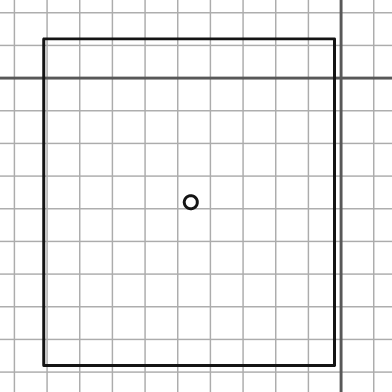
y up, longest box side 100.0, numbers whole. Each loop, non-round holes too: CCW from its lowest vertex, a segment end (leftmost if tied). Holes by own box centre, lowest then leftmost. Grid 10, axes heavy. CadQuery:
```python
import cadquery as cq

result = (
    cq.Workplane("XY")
    .moveTo(-91.0, -88.0)
    .lineTo(-2.0, -88.0)
    .lineTo(-2.0, 12.0)
    .lineTo(-91.0, 12.0)
    .close()
    .moveTo(-46.0, -38.0)
    .circle(2.0)
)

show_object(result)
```